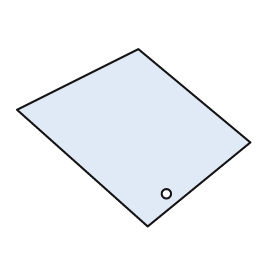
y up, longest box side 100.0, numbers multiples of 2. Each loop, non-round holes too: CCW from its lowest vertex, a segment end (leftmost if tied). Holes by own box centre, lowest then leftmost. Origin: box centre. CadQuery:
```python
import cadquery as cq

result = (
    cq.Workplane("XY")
    .moveTo(6.0, -38.0)
    .lineTo(50.0, -2.0)
    .lineTo(2.0, 38.0)
    .lineTo(-50.0, 12.0)
    .close()
    .moveTo(14.0, -24.0)
    .circle(2.0)
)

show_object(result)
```